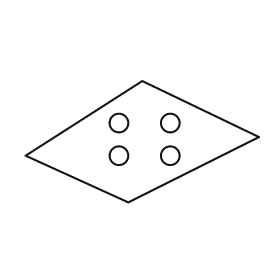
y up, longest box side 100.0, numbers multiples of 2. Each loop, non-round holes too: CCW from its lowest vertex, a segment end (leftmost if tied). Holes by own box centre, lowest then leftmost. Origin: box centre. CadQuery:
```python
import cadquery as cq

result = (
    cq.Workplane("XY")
    .moveTo(-6.0, -26.0)
    .lineTo(50.0, 2.0)
    .lineTo(0.0, 26.0)
    .lineTo(-50.0, -6.0)
    .close()
    .moveTo(-10.0, -6.0)
    .circle(4.0)
    .moveTo(12.0, -6.0)
    .circle(4.0)
    .moveTo(-10.0, 8.0)
    .circle(4.0)
    .moveTo(12.0, 8.0)
    .circle(4.0)
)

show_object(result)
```